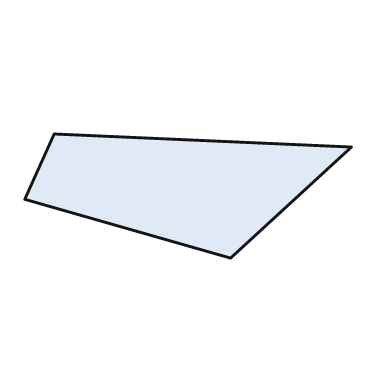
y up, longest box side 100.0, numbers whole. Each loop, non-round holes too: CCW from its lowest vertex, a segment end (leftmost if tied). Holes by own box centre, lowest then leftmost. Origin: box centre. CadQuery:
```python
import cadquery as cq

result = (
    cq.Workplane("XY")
    .moveTo(13.0, -19.0)
    .lineTo(50.0, 15.0)
    .lineTo(-41.0, 19.0)
    .lineTo(-50.0, -1.0)
    .close()
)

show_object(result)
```